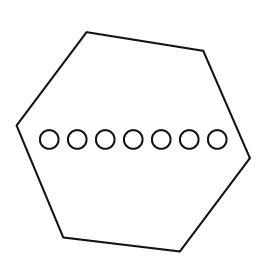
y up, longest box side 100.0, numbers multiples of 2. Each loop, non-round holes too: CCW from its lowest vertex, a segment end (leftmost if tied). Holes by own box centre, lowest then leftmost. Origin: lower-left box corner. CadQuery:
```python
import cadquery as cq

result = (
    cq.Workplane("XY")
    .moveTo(70.0, 0.0)
    .lineTo(100.0, 40.0)
    .lineTo(80.0, 86.0)
    .lineTo(30.0, 94.0)
    .lineTo(0.0, 54.0)
    .lineTo(20.0, 6.0)
    .close()
    .moveTo(14.0, 48.0)
    .circle(4.0)
    .moveTo(26.0, 48.0)
    .circle(4.0)
    .moveTo(38.0, 48.0)
    .circle(4.0)
    .moveTo(50.0, 48.0)
    .circle(4.0)
    .moveTo(62.0, 48.0)
    .circle(4.0)
    .moveTo(74.0, 48.0)
    .circle(4.0)
    .moveTo(86.0, 48.0)
    .circle(4.0)
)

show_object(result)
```